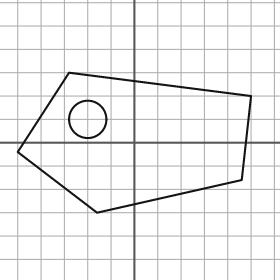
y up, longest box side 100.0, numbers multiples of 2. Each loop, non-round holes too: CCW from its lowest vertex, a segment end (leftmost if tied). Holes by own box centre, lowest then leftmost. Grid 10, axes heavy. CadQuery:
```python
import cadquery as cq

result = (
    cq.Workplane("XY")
    .moveTo(-16.0, -30.0)
    .lineTo(46.0, -16.0)
    .lineTo(50.0, 20.0)
    .lineTo(-28.0, 30.0)
    .lineTo(-50.0, -4.0)
    .close()
    .moveTo(-20.0, 10.0)
    .circle(8.0)
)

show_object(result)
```